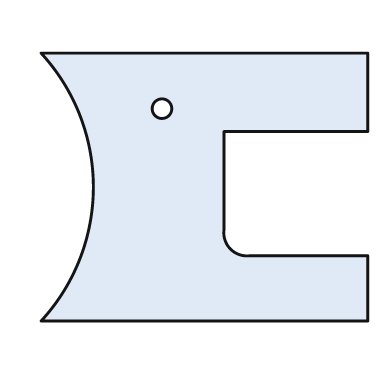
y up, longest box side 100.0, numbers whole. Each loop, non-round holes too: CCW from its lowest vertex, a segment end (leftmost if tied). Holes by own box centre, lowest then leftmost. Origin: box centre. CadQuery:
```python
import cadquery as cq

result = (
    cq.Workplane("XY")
    .moveTo(-50.0, -41.0)
    .lineTo(50.0, -41.0)
    .lineTo(50.0, -21.0)
    .lineTo(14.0, -21.0)
    .threePointArc((8.0, -19.0), (6.0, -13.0))
    .lineTo(6.0, 17.0)
    .lineTo(50.0, 17.0)
    .lineTo(50.0, 41.0)
    .lineTo(-50.0, 41.0)
    .threePointArc((-34.0, 0.0), (-50.0, -41.0))
    .close()
    .moveTo(-13.0, 24.0)
    .circle(3.0)
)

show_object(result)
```